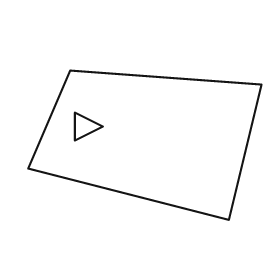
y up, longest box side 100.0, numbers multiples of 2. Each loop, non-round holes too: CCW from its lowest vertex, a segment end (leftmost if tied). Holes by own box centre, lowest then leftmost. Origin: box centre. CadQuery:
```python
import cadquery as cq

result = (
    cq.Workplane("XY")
    .moveTo(36.0, -32.0)
    .lineTo(50.0, 26.0)
    .lineTo(-32.0, 32.0)
    .lineTo(-50.0, -10.0)
    .close()
    .moveTo(-30.0, 2.0)
    .lineTo(-18.0, 8.0)
    .lineTo(-30.0, 14.0)
    .close()
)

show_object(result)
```